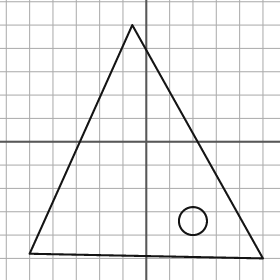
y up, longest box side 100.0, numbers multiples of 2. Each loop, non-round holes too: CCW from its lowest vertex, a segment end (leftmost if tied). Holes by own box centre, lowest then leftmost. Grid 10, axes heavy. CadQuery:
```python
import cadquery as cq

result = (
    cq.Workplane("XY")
    .moveTo(50.0, -50.0)
    .lineTo(-6.0, 50.0)
    .lineTo(-50.0, -48.0)
    .close()
    .moveTo(20.0, -34.0)
    .circle(6.0)
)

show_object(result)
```